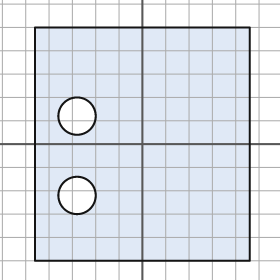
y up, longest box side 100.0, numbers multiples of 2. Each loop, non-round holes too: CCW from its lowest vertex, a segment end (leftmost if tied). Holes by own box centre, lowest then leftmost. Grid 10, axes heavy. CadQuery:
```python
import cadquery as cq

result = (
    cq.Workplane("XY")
    .moveTo(-46.0, -50.0)
    .lineTo(46.0, -50.0)
    .lineTo(46.0, 50.0)
    .lineTo(-46.0, 50.0)
    .close()
    .moveTo(-28.0, -22.0)
    .circle(8.0)
    .moveTo(-28.0, 12.0)
    .circle(8.0)
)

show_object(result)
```